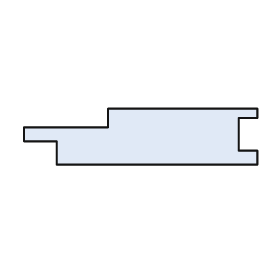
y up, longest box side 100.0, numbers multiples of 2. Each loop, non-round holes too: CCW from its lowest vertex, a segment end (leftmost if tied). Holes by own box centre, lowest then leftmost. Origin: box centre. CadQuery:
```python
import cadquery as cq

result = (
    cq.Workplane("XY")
    .moveTo(-36.0, -12.0)
    .lineTo(50.0, -12.0)
    .lineTo(50.0, -6.0)
    .lineTo(42.0, -6.0)
    .lineTo(42.0, 8.0)
    .lineTo(50.0, 8.0)
    .lineTo(50.0, 12.0)
    .lineTo(-14.0, 12.0)
    .lineTo(-14.0, 4.0)
    .lineTo(-50.0, 4.0)
    .lineTo(-50.0, -2.0)
    .lineTo(-36.0, -2.0)
    .close()
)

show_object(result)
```